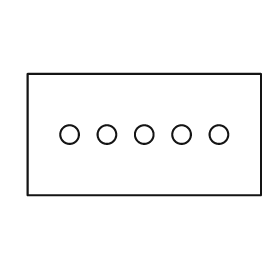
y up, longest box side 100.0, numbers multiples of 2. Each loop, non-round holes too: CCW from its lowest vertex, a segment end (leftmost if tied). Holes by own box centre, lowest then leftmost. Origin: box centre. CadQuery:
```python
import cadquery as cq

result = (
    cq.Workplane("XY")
    .moveTo(-50.0, -26.0)
    .lineTo(50.0, -26.0)
    .lineTo(50.0, 26.0)
    .lineTo(-50.0, 26.0)
    .close()
    .moveTo(-32.0, 0.0)
    .circle(4.0)
    .moveTo(-16.0, 0.0)
    .circle(4.0)
    .moveTo(0.0, 0.0)
    .circle(4.0)
    .moveTo(16.0, 0.0)
    .circle(4.0)
    .moveTo(32.0, 0.0)
    .circle(4.0)
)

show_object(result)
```